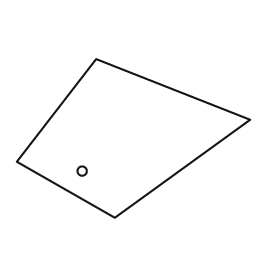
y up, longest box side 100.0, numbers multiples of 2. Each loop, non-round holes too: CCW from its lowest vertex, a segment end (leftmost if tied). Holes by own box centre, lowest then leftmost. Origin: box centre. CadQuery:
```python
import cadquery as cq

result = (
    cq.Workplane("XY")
    .moveTo(-8.0, -34.0)
    .lineTo(50.0, 8.0)
    .lineTo(-16.0, 34.0)
    .lineTo(-50.0, -10.0)
    .close()
    .moveTo(-22.0, -14.0)
    .circle(2.0)
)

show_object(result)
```